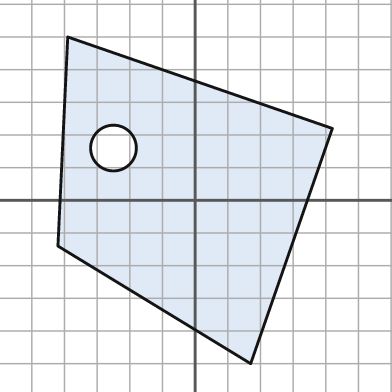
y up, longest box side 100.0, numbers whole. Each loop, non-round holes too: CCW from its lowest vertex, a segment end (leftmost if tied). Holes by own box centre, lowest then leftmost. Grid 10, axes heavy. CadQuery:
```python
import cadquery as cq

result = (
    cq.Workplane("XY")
    .moveTo(17.0, -50.0)
    .lineTo(42.0, 22.0)
    .lineTo(-39.0, 50.0)
    .lineTo(-42.0, -14.0)
    .close()
    .moveTo(-25.0, 16.0)
    .circle(7.0)
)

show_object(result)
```